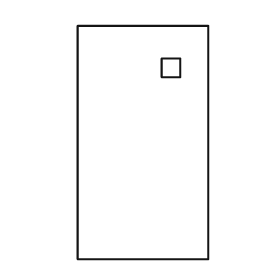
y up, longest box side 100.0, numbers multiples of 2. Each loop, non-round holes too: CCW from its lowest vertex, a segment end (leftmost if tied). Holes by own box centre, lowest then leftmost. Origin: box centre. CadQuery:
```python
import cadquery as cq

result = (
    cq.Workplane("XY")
    .moveTo(-28.0, -50.0)
    .lineTo(28.0, -50.0)
    .lineTo(28.0, 50.0)
    .lineTo(-28.0, 50.0)
    .close()
    .moveTo(8.0, 28.0)
    .lineTo(16.0, 28.0)
    .lineTo(16.0, 36.0)
    .lineTo(8.0, 36.0)
    .close()
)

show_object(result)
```